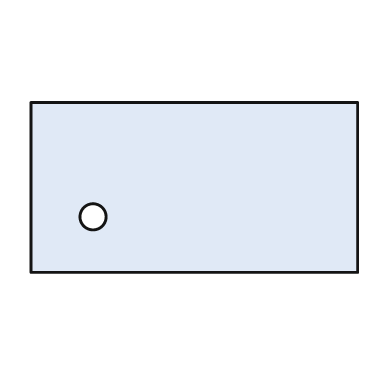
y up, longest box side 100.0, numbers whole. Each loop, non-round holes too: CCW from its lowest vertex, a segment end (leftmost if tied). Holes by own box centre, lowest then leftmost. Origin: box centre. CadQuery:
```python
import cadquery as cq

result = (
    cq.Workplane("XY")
    .moveTo(-50.0, -26.0)
    .lineTo(50.0, -26.0)
    .lineTo(50.0, 26.0)
    .lineTo(-50.0, 26.0)
    .close()
    .moveTo(-31.0, -9.0)
    .circle(4.0)
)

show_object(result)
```